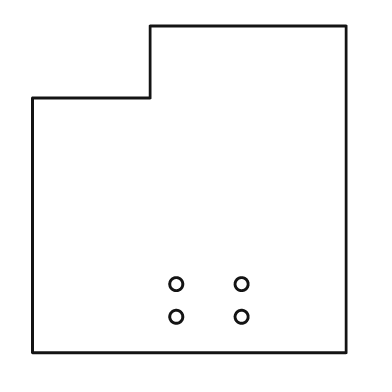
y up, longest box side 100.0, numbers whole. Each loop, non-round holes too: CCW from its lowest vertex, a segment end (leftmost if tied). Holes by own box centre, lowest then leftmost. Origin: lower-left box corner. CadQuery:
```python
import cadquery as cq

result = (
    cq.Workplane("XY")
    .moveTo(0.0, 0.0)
    .lineTo(96.0, 0.0)
    .lineTo(96.0, 100.0)
    .lineTo(36.0, 100.0)
    .lineTo(36.0, 78.0)
    .lineTo(0.0, 78.0)
    .close()
    .moveTo(44.0, 11.0)
    .circle(2.0)
    .moveTo(64.0, 11.0)
    .circle(2.0)
    .moveTo(44.0, 21.0)
    .circle(2.0)
    .moveTo(64.0, 21.0)
    .circle(2.0)
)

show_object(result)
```